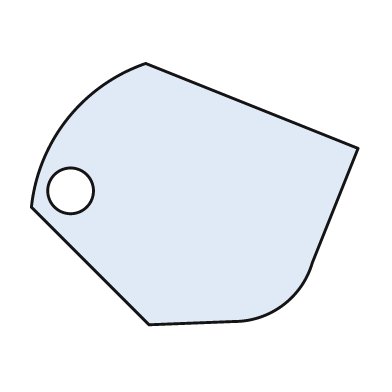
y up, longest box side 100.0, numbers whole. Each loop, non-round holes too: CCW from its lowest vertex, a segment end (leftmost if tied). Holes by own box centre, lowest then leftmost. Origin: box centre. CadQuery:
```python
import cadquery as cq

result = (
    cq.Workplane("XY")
    .moveTo(-14.0, -40.0)
    .lineTo(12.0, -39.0)
    .threePointArc((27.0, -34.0), (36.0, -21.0))
    .lineTo(50.0, 14.0)
    .lineTo(-15.0, 40.0)
    .threePointArc((-39.0, 23.0), (-50.0, -4.0))
    .close()
    .moveTo(-38.0, 1.0)
    .circle(7.0)
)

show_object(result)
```